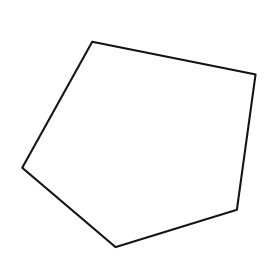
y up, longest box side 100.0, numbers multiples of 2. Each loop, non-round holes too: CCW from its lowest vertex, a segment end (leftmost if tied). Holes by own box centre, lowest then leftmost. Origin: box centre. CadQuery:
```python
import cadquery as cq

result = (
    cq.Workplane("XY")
    .moveTo(-10.0, -44.0)
    .lineTo(42.0, -28.0)
    .lineTo(50.0, 30.0)
    .lineTo(-20.0, 44.0)
    .lineTo(-50.0, -10.0)
    .close()
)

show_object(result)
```